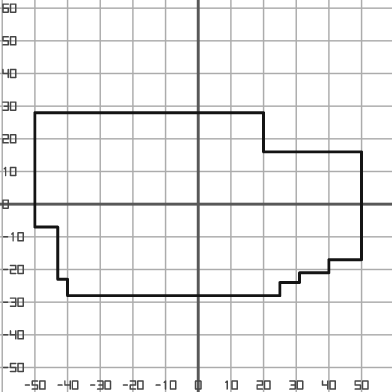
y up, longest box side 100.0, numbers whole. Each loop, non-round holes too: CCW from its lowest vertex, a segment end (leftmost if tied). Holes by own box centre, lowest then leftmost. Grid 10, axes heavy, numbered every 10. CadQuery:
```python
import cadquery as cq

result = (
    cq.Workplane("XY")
    .moveTo(-40.0, -28.0)
    .lineTo(25.0, -28.0)
    .lineTo(25.0, -24.0)
    .lineTo(31.0, -24.0)
    .lineTo(31.0, -21.0)
    .lineTo(40.0, -21.0)
    .lineTo(40.0, -17.0)
    .lineTo(50.0, -17.0)
    .lineTo(50.0, 16.0)
    .lineTo(20.0, 16.0)
    .lineTo(20.0, 28.0)
    .lineTo(-50.0, 28.0)
    .lineTo(-50.0, -7.0)
    .lineTo(-43.0, -7.0)
    .lineTo(-43.0, -23.0)
    .lineTo(-40.0, -23.0)
    .close()
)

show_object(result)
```